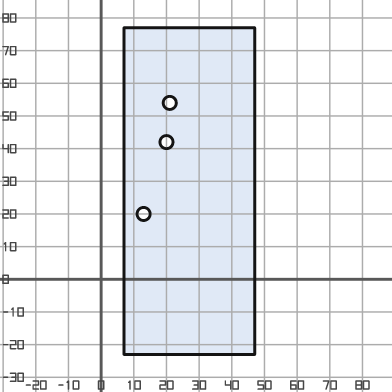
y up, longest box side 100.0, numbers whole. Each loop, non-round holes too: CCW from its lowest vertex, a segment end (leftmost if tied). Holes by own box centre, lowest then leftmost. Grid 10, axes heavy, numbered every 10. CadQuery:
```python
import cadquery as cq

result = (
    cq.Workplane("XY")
    .moveTo(7.0, -23.0)
    .lineTo(47.0, -23.0)
    .lineTo(47.0, 77.0)
    .lineTo(7.0, 77.0)
    .close()
    .moveTo(13.0, 20.0)
    .circle(2.0)
    .moveTo(20.0, 42.0)
    .circle(2.0)
    .moveTo(21.0, 54.0)
    .circle(2.0)
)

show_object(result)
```